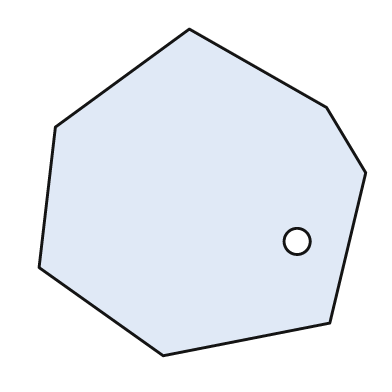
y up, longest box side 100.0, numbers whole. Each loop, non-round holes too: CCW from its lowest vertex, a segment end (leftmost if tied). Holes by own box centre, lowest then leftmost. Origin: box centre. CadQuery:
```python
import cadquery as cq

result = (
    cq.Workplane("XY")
    .moveTo(-12.0, -50.0)
    .lineTo(39.0, -40.0)
    .lineTo(50.0, 6.0)
    .lineTo(38.0, 26.0)
    .lineTo(-4.0, 50.0)
    .lineTo(-45.0, 20.0)
    .lineTo(-50.0, -23.0)
    .close()
    .moveTo(29.0, -15.0)
    .circle(4.0)
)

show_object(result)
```